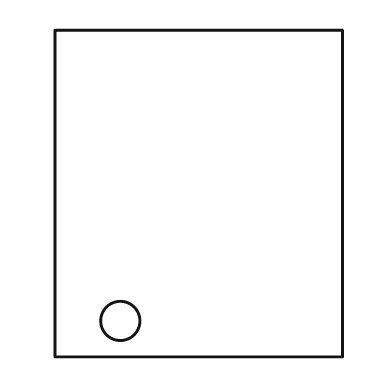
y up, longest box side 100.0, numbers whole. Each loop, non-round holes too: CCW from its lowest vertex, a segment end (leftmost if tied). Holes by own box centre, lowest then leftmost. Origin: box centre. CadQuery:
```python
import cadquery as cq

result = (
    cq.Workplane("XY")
    .moveTo(-44.0, -50.0)
    .lineTo(44.0, -50.0)
    .lineTo(44.0, 50.0)
    .lineTo(-44.0, 50.0)
    .close()
    .moveTo(-24.0, -39.0)
    .circle(6.0)
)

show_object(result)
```